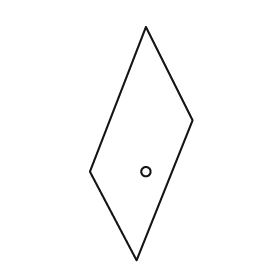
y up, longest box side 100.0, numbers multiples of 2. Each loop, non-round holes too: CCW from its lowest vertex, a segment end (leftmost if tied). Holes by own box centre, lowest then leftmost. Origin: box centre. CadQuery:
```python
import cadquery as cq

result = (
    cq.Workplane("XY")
    .moveTo(-2.0, -50.0)
    .lineTo(22.0, 10.0)
    .lineTo(2.0, 50.0)
    .lineTo(-22.0, -12.0)
    .close()
    .moveTo(2.0, -12.0)
    .circle(2.0)
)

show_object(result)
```